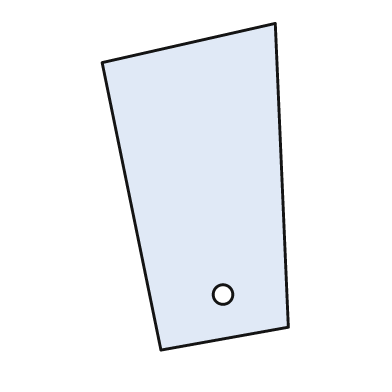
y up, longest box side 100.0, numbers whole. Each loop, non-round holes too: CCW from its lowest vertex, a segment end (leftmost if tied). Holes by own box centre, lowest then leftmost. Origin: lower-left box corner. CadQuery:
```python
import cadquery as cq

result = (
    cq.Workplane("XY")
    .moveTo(18.0, 0.0)
    .lineTo(57.0, 7.0)
    .lineTo(53.0, 100.0)
    .lineTo(0.0, 88.0)
    .close()
    .moveTo(37.0, 17.0)
    .circle(3.0)
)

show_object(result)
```